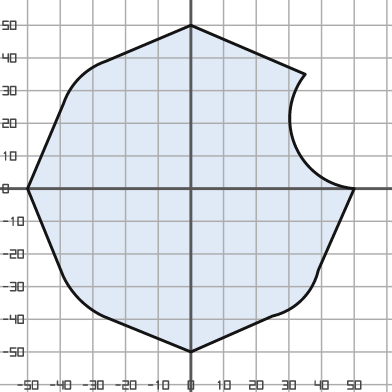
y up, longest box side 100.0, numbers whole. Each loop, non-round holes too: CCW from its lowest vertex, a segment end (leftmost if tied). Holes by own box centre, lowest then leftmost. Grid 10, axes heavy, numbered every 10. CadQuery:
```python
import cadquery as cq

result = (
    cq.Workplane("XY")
    .moveTo(0.0, -50.0)
    .lineTo(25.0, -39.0)
    .threePointArc((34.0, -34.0), (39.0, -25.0))
    .lineTo(50.0, 0.0)
    .threePointArc((32.0, 13.0), (35.0, 35.0))
    .lineTo(0.0, 50.0)
    .lineTo(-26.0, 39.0)
    .threePointArc((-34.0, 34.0), (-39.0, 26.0))
    .lineTo(-50.0, 0.0)
    .lineTo(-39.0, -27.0)
    .threePointArc((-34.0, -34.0), (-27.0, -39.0))
    .close()
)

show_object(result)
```